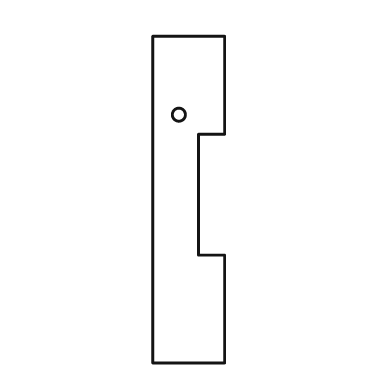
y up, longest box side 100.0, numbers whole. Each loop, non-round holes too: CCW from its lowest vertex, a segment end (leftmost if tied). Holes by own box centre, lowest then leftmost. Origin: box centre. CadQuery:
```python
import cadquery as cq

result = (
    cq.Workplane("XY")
    .moveTo(-11.0, -50.0)
    .lineTo(11.0, -50.0)
    .lineTo(11.0, -17.0)
    .lineTo(3.0, -17.0)
    .lineTo(3.0, 20.0)
    .lineTo(11.0, 20.0)
    .lineTo(11.0, 50.0)
    .lineTo(-11.0, 50.0)
    .close()
    .moveTo(-3.0, 26.0)
    .circle(2.0)
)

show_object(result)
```